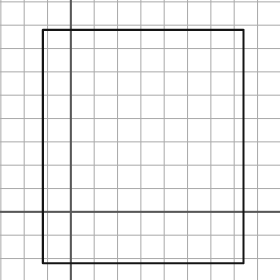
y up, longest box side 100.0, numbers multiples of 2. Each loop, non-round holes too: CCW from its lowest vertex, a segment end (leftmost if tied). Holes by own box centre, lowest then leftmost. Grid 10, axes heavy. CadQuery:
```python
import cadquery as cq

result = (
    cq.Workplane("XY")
    .moveTo(-12.0, -22.0)
    .lineTo(74.0, -22.0)
    .lineTo(74.0, 78.0)
    .lineTo(-12.0, 78.0)
    .close()
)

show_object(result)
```